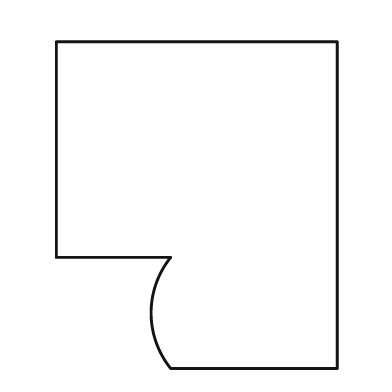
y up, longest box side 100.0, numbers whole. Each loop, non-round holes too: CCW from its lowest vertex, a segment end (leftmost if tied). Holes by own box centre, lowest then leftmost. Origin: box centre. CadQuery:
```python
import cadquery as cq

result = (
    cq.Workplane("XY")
    .moveTo(-8.0, -50.0)
    .lineTo(43.0, -50.0)
    .lineTo(43.0, 50.0)
    .lineTo(-43.0, 50.0)
    .lineTo(-43.0, -16.0)
    .lineTo(-8.0, -16.0)
    .threePointArc((-14.0, -33.0), (-8.0, -50.0))
    .close()
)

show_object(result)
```